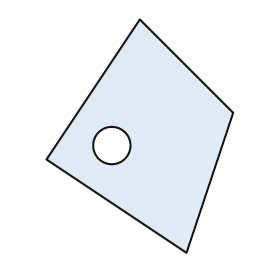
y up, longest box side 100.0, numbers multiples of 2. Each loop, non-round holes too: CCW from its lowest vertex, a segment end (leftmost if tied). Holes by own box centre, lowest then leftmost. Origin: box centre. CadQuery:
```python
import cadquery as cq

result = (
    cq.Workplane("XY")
    .moveTo(20.0, -50.0)
    .lineTo(40.0, 10.0)
    .lineTo(0.0, 50.0)
    .lineTo(-40.0, -10.0)
    .close()
    .moveTo(-12.0, -4.0)
    .circle(8.0)
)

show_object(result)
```